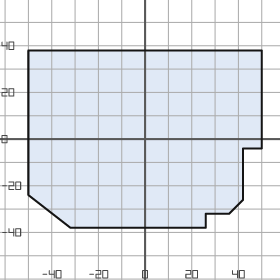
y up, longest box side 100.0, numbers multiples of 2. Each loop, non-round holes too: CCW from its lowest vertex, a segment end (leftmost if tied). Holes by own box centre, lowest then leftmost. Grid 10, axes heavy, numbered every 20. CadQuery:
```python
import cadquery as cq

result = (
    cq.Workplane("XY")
    .moveTo(-32.0, -38.0)
    .lineTo(26.0, -38.0)
    .lineTo(26.0, -32.0)
    .lineTo(36.0, -32.0)
    .lineTo(42.0, -26.0)
    .lineTo(42.0, -4.0)
    .lineTo(50.0, -4.0)
    .lineTo(50.0, 38.0)
    .lineTo(-50.0, 38.0)
    .lineTo(-50.0, -24.0)
    .close()
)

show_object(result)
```